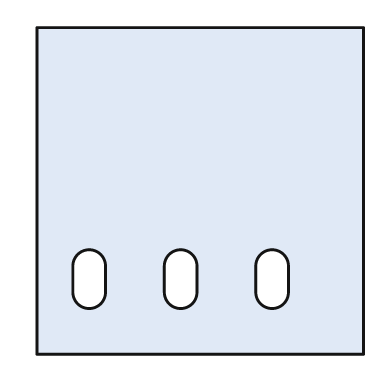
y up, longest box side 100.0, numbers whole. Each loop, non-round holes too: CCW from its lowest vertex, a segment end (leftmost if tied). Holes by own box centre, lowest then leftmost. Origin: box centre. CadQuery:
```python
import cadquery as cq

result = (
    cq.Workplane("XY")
    .moveTo(-50.0, -50.0)
    .lineTo(50.0, -50.0)
    .lineTo(50.0, 50.0)
    .lineTo(-50.0, 50.0)
    .close()
    .moveTo(-39.0, -31.0)
    .threePointArc((-34.0, -36.0), (-29.0, -31.0))
    .lineTo(-29.0, -23.0)
    .threePointArc((-34.0, -18.0), (-39.0, -23.0))
    .close()
    .moveTo(-11.0, -31.0)
    .threePointArc((-6.0, -36.0), (-1.0, -31.0))
    .lineTo(-1.0, -23.0)
    .threePointArc((-6.0, -18.0), (-11.0, -23.0))
    .close()
    .moveTo(17.0, -31.0)
    .threePointArc((22.0, -36.0), (27.0, -31.0))
    .lineTo(27.0, -23.0)
    .threePointArc((22.0, -18.0), (17.0, -23.0))
    .close()
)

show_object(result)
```